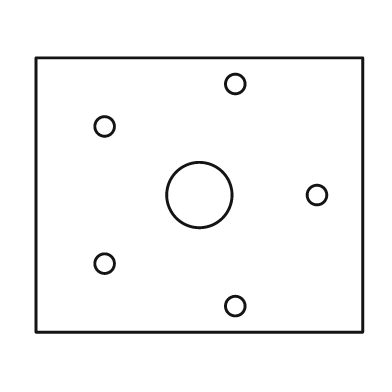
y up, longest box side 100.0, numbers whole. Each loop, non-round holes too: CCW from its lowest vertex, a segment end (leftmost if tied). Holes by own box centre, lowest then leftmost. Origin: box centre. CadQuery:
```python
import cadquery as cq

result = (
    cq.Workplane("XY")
    .moveTo(-50.0, -42.0)
    .lineTo(50.0, -42.0)
    .lineTo(50.0, 42.0)
    .lineTo(-50.0, 42.0)
    .close()
    .moveTo(11.0, -34.0)
    .circle(3.0)
    .moveTo(-29.0, -21.0)
    .circle(3.0)
    .moveTo(0.0, 0.0)
    .circle(10.0)
    .moveTo(36.0, 0.0)
    .circle(3.0)
    .moveTo(-29.0, 21.0)
    .circle(3.0)
    .moveTo(11.0, 34.0)
    .circle(3.0)
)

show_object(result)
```